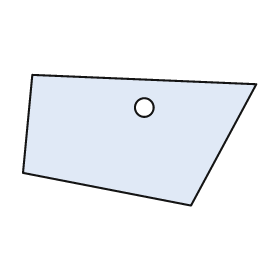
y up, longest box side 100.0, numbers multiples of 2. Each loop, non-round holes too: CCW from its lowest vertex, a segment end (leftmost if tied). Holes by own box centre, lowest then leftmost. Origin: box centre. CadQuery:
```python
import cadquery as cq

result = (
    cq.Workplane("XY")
    .moveTo(22.0, -28.0)
    .lineTo(50.0, 24.0)
    .lineTo(-46.0, 28.0)
    .lineTo(-50.0, -14.0)
    .close()
    .moveTo(2.0, 14.0)
    .circle(4.0)
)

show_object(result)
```